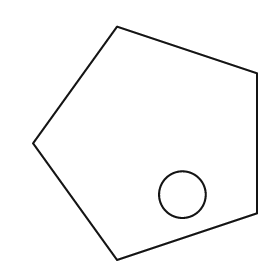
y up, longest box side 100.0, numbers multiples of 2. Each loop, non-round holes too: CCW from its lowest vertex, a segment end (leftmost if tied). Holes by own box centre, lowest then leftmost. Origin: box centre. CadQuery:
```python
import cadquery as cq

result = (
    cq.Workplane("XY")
    .moveTo(-12.0, -50.0)
    .lineTo(48.0, -30.0)
    .lineTo(48.0, 30.0)
    .lineTo(-12.0, 50.0)
    .lineTo(-48.0, 0.0)
    .close()
    .moveTo(16.0, -22.0)
    .circle(10.0)
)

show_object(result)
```